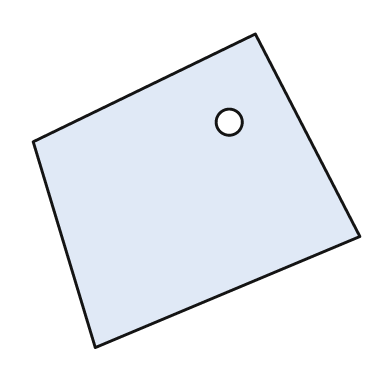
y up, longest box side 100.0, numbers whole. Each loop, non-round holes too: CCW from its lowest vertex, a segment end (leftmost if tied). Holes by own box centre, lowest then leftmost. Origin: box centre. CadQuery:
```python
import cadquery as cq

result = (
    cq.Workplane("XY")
    .moveTo(-31.0, -48.0)
    .lineTo(50.0, -14.0)
    .lineTo(18.0, 48.0)
    .lineTo(-50.0, 15.0)
    .close()
    .moveTo(10.0, 21.0)
    .circle(4.0)
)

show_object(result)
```